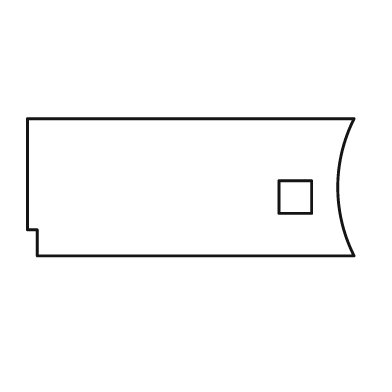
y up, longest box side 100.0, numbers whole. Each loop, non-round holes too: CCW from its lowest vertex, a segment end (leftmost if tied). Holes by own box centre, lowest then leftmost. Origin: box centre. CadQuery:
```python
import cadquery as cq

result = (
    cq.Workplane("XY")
    .moveTo(-47.0, -21.0)
    .lineTo(50.0, -21.0)
    .threePointArc((45.0, 0.0), (50.0, 21.0))
    .lineTo(-50.0, 21.0)
    .lineTo(-50.0, -13.0)
    .lineTo(-47.0, -13.0)
    .close()
    .moveTo(27.0, -8.0)
    .lineTo(37.0, -8.0)
    .lineTo(37.0, 2.0)
    .lineTo(27.0, 2.0)
    .close()
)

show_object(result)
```